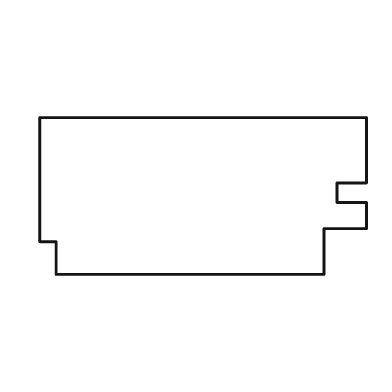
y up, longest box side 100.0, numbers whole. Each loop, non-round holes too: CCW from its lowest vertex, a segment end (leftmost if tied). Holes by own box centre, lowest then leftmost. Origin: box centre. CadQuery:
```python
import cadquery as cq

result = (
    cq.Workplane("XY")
    .moveTo(-45.0, -24.0)
    .lineTo(37.0, -24.0)
    .lineTo(37.0, -10.0)
    .lineTo(50.0, -10.0)
    .lineTo(50.0, -2.0)
    .lineTo(41.0, -2.0)
    .lineTo(41.0, 4.0)
    .lineTo(50.0, 4.0)
    .lineTo(50.0, 24.0)
    .lineTo(-50.0, 24.0)
    .lineTo(-50.0, -14.0)
    .lineTo(-45.0, -14.0)
    .close()
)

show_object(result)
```